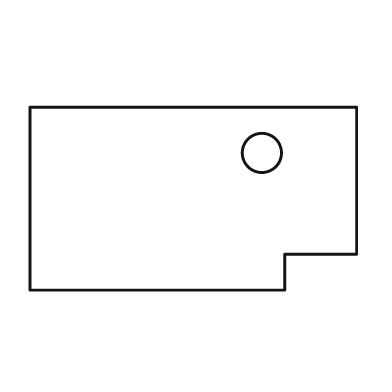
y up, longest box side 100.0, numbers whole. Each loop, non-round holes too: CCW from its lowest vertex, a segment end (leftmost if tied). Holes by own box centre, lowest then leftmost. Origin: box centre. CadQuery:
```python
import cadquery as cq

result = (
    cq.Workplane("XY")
    .moveTo(-50.0, -28.0)
    .lineTo(28.0, -28.0)
    .lineTo(28.0, -17.0)
    .lineTo(50.0, -17.0)
    .lineTo(50.0, 28.0)
    .lineTo(-50.0, 28.0)
    .close()
    .moveTo(21.0, 14.0)
    .circle(6.0)
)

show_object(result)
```